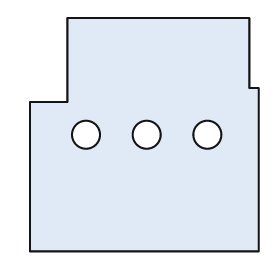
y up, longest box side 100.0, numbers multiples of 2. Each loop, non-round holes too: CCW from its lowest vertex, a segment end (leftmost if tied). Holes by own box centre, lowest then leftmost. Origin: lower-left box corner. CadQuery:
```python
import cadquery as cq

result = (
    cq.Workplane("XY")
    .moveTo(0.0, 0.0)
    .lineTo(98.0, 0.0)
    .lineTo(98.0, 70.0)
    .lineTo(94.0, 70.0)
    .lineTo(94.0, 100.0)
    .lineTo(16.0, 100.0)
    .lineTo(16.0, 64.0)
    .lineTo(0.0, 64.0)
    .close()
    .moveTo(24.0, 50.0)
    .circle(6.0)
    .moveTo(50.0, 50.0)
    .circle(6.0)
    .moveTo(76.0, 50.0)
    .circle(6.0)
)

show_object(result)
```